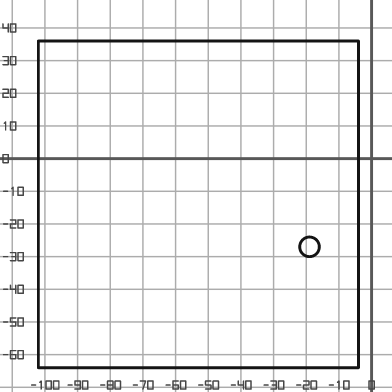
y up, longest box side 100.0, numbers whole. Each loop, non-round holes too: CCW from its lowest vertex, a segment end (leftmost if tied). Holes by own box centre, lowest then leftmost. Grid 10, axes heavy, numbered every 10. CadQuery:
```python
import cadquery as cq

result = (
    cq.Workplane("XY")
    .moveTo(-102.0, -64.0)
    .lineTo(-4.0, -64.0)
    .lineTo(-4.0, 36.0)
    .lineTo(-102.0, 36.0)
    .close()
    .moveTo(-19.0, -27.0)
    .circle(3.0)
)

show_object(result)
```